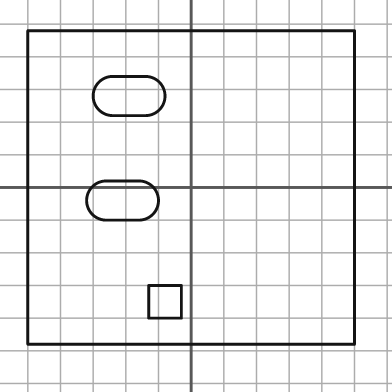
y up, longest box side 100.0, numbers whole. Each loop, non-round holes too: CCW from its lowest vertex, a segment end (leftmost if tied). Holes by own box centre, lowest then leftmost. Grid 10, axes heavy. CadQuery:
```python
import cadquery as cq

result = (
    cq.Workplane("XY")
    .moveTo(-50.0, -48.0)
    .lineTo(50.0, -48.0)
    .lineTo(50.0, 48.0)
    .lineTo(-50.0, 48.0)
    .close()
    .moveTo(-13.0, -40.0)
    .lineTo(-3.0, -40.0)
    .lineTo(-3.0, -30.0)
    .lineTo(-13.0, -30.0)
    .close()
    .moveTo(-26.0, -10.0)
    .lineTo(-16.0, -10.0)
    .threePointArc((-10.0, -4.0), (-16.0, 2.0))
    .lineTo(-26.0, 2.0)
    .threePointArc((-32.0, -4.0), (-26.0, -10.0))
    .close()
    .moveTo(-24.0, 22.0)
    .lineTo(-14.0, 22.0)
    .threePointArc((-8.0, 28.0), (-14.0, 34.0))
    .lineTo(-24.0, 34.0)
    .threePointArc((-30.0, 28.0), (-24.0, 22.0))
    .close()
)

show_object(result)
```